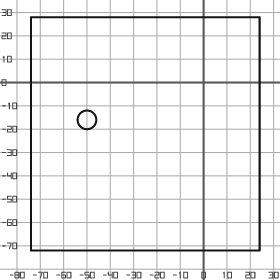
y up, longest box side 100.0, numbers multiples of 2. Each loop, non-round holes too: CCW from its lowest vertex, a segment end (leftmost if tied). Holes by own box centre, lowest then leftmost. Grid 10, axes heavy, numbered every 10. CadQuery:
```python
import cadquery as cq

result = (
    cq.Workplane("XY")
    .moveTo(-74.0, -72.0)
    .lineTo(24.0, -72.0)
    .lineTo(24.0, 28.0)
    .lineTo(-74.0, 28.0)
    .close()
    .moveTo(-50.0, -16.0)
    .circle(4.0)
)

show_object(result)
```